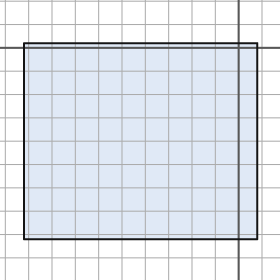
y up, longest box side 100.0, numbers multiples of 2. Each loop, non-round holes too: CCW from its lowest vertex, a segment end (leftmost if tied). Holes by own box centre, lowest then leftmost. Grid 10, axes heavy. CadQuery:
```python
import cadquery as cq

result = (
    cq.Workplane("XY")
    .moveTo(-92.0, -82.0)
    .lineTo(8.0, -82.0)
    .lineTo(8.0, 2.0)
    .lineTo(-92.0, 2.0)
    .close()
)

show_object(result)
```